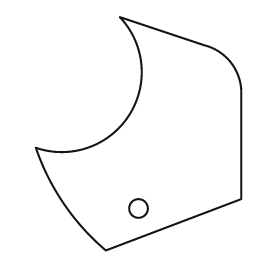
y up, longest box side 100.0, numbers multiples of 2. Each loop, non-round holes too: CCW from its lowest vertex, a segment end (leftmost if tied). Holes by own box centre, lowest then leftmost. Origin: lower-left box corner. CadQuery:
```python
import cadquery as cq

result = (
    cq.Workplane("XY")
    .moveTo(30.0, 0.0)
    .lineTo(88.0, 22.0)
    .lineTo(88.0, 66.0)
    .threePointArc((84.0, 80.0), (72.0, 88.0))
    .lineTo(36.0, 100.0)
    .threePointArc((40.0, 58.0), (0.0, 44.0))
    .threePointArc((12.0, 20.0), (30.0, 0.0))
    .close()
    .moveTo(44.0, 18.0)
    .circle(4.0)
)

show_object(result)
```